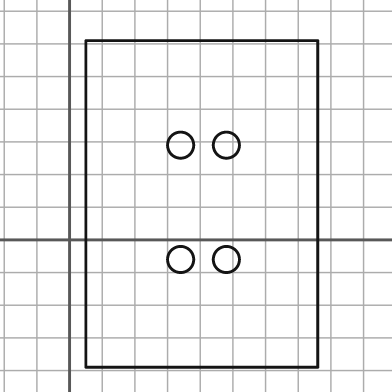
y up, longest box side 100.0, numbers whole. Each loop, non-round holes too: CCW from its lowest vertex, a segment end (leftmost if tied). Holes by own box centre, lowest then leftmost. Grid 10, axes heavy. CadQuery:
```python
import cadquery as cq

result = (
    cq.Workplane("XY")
    .moveTo(5.0, -39.0)
    .lineTo(76.0, -39.0)
    .lineTo(76.0, 61.0)
    .lineTo(5.0, 61.0)
    .close()
    .moveTo(34.0, -6.0)
    .circle(4.0)
    .moveTo(48.0, -6.0)
    .circle(4.0)
    .moveTo(34.0, 29.0)
    .circle(4.0)
    .moveTo(48.0, 29.0)
    .circle(4.0)
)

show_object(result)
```